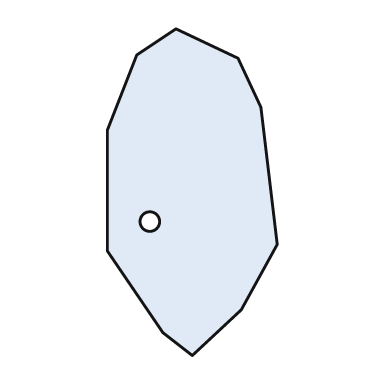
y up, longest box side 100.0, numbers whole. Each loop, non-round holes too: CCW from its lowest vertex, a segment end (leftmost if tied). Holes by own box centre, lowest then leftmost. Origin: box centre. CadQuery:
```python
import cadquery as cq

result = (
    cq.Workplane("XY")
    .moveTo(0.0, -50.0)
    .lineTo(15.0, -36.0)
    .lineTo(26.0, -16.0)
    .lineTo(21.0, 26.0)
    .lineTo(14.0, 41.0)
    .lineTo(-5.0, 50.0)
    .lineTo(-17.0, 42.0)
    .lineTo(-26.0, 19.0)
    .lineTo(-26.0, -18.0)
    .lineTo(-9.0, -43.0)
    .close()
    .moveTo(-13.0, -9.0)
    .circle(3.0)
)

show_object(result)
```